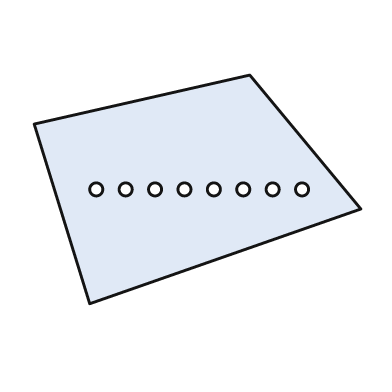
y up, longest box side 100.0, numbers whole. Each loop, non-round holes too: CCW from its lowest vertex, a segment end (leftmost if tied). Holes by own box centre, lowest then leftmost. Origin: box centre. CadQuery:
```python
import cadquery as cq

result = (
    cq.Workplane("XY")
    .moveTo(-33.0, -35.0)
    .lineTo(50.0, -6.0)
    .lineTo(16.0, 35.0)
    .lineTo(-50.0, 20.0)
    .close()
    .moveTo(-31.0, 0.0)
    .circle(2.0)
    .moveTo(-22.0, 0.0)
    .circle(2.0)
    .moveTo(-13.0, 0.0)
    .circle(2.0)
    .moveTo(-4.0, 0.0)
    .circle(2.0)
    .moveTo(5.0, 0.0)
    .circle(2.0)
    .moveTo(14.0, 0.0)
    .circle(2.0)
    .moveTo(23.0, 0.0)
    .circle(2.0)
    .moveTo(32.0, 0.0)
    .circle(2.0)
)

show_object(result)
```